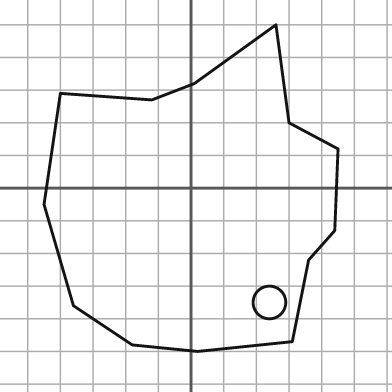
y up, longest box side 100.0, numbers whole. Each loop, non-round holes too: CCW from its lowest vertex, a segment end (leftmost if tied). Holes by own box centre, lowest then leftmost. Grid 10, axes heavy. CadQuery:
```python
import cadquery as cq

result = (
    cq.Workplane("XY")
    .moveTo(2.0, -50.0)
    .lineTo(31.0, -47.0)
    .lineTo(36.0, -22.0)
    .lineTo(44.0, -13.0)
    .lineTo(45.0, 12.0)
    .lineTo(30.0, 20.0)
    .lineTo(26.0, 50.0)
    .lineTo(1.0, 32.0)
    .lineTo(-12.0, 27.0)
    .lineTo(-40.0, 29.0)
    .lineTo(-45.0, -5.0)
    .lineTo(-36.0, -36.0)
    .lineTo(-18.0, -48.0)
    .close()
    .moveTo(24.0, -35.0)
    .circle(5.0)
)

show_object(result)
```